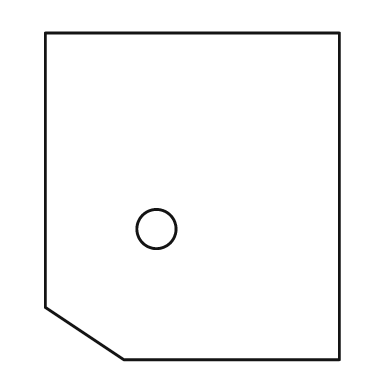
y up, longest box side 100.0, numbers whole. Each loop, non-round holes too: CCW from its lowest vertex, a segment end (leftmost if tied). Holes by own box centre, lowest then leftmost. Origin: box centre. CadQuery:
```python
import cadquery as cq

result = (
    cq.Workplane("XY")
    .moveTo(-21.0, -50.0)
    .lineTo(45.0, -50.0)
    .lineTo(45.0, 50.0)
    .lineTo(-45.0, 50.0)
    .lineTo(-45.0, -34.0)
    .close()
    .moveTo(-11.0, -10.0)
    .circle(6.0)
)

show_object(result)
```